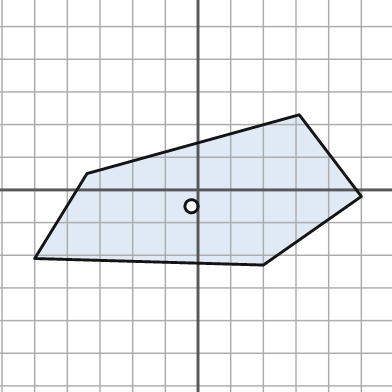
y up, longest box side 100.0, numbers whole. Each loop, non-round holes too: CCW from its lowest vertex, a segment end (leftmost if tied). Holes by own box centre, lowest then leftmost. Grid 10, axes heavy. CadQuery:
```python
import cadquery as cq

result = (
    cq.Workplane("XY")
    .moveTo(20.0, -23.0)
    .lineTo(50.0, -2.0)
    .lineTo(31.0, 23.0)
    .lineTo(-34.0, 5.0)
    .lineTo(-50.0, -21.0)
    .close()
    .moveTo(-2.0, -5.0)
    .circle(2.0)
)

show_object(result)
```